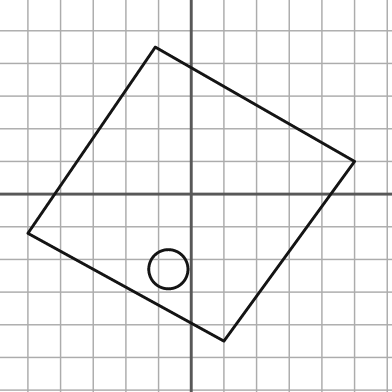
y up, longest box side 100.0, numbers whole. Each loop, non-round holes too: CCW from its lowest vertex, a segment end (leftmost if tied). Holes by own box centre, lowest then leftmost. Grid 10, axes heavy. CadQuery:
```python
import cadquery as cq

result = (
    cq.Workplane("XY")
    .moveTo(10.0, -45.0)
    .lineTo(50.0, 10.0)
    .lineTo(-11.0, 45.0)
    .lineTo(-50.0, -12.0)
    .close()
    .moveTo(-7.0, -23.0)
    .circle(6.0)
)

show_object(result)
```